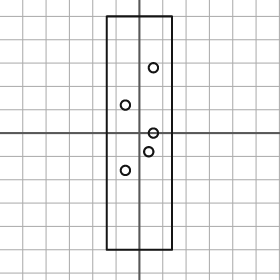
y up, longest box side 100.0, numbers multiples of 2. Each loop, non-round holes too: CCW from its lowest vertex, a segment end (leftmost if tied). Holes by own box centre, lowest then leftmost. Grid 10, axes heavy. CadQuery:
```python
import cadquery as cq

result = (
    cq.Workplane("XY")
    .moveTo(-14.0, -50.0)
    .lineTo(14.0, -50.0)
    .lineTo(14.0, 50.0)
    .lineTo(-14.0, 50.0)
    .close()
    .moveTo(-6.0, -16.0)
    .circle(2.0)
    .moveTo(4.0, -8.0)
    .circle(2.0)
    .moveTo(6.0, 0.0)
    .circle(2.0)
    .moveTo(-6.0, 12.0)
    .circle(2.0)
    .moveTo(6.0, 28.0)
    .circle(2.0)
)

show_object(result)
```